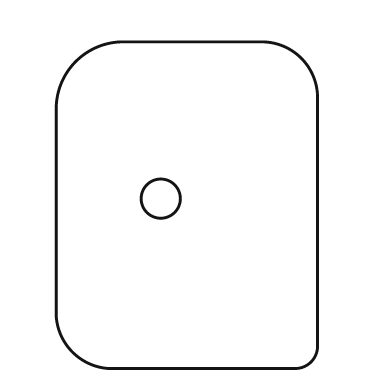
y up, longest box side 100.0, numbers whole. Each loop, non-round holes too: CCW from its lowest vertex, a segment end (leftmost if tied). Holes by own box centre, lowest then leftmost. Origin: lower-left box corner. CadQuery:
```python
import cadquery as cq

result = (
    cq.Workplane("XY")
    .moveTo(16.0, 0.0)
    .lineTo(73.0, 0.0)
    .threePointArc((78.0, 2.0), (80.0, 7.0))
    .lineTo(80.0, 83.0)
    .threePointArc((75.0, 95.0), (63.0, 100.0))
    .lineTo(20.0, 100.0)
    .threePointArc((6.0, 94.0), (0.0, 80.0))
    .lineTo(0.0, 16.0)
    .threePointArc((5.0, 5.0), (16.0, 0.0))
    .close()
    .moveTo(32.0, 52.0)
    .circle(6.0)
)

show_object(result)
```